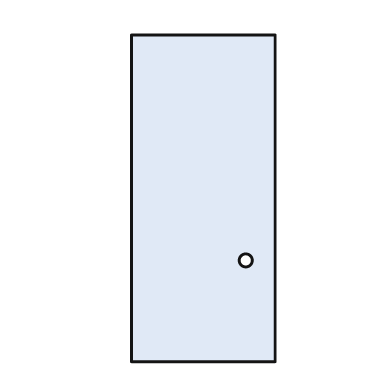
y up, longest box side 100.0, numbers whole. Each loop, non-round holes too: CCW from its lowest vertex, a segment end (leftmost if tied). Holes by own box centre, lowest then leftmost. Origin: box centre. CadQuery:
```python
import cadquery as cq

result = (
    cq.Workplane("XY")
    .moveTo(-22.0, -50.0)
    .lineTo(22.0, -50.0)
    .lineTo(22.0, 50.0)
    .lineTo(-22.0, 50.0)
    .close()
    .moveTo(13.0, -19.0)
    .circle(2.0)
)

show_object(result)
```